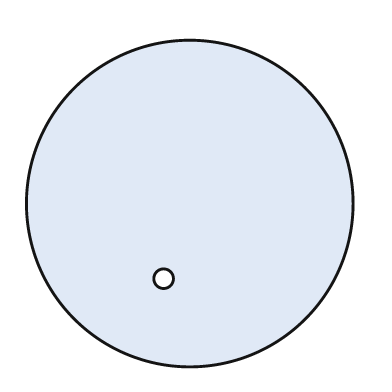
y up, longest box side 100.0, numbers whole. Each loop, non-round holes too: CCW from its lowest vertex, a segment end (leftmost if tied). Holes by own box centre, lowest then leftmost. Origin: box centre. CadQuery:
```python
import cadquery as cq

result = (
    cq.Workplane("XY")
    .moveTo(0.0, 0.0)
    .circle(50.0)
    .moveTo(-8.0, -23.0)
    .circle(3.0)
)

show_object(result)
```